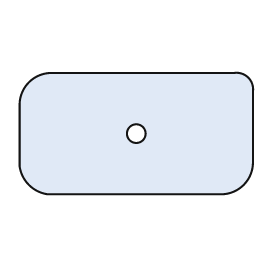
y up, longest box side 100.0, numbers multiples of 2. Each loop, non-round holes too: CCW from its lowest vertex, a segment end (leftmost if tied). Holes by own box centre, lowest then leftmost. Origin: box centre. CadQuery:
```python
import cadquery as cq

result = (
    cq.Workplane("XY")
    .moveTo(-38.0, -26.0)
    .lineTo(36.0, -26.0)
    .threePointArc((46.0, -22.0), (50.0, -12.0))
    .lineTo(50.0, 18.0)
    .threePointArc((48.0, 24.0), (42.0, 26.0))
    .lineTo(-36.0, 26.0)
    .threePointArc((-46.0, 22.0), (-50.0, 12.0))
    .lineTo(-50.0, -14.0)
    .threePointArc((-46.0, -22.0), (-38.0, -26.0))
    .close()
    .moveTo(0.0, 0.0)
    .circle(4.0)
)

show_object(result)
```